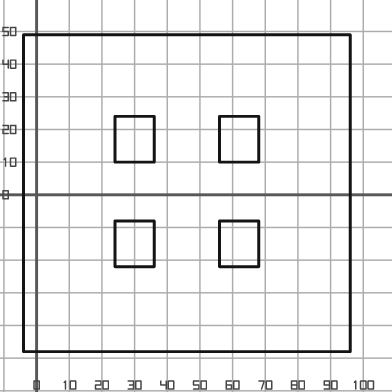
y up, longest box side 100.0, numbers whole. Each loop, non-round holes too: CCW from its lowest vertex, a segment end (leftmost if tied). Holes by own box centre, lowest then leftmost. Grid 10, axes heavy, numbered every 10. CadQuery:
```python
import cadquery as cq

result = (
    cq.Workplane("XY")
    .moveTo(-4.0, -48.0)
    .lineTo(96.0, -48.0)
    .lineTo(96.0, 49.0)
    .lineTo(-4.0, 49.0)
    .close()
    .moveTo(24.0, -22.0)
    .lineTo(36.0, -22.0)
    .lineTo(36.0, -8.0)
    .lineTo(24.0, -8.0)
    .close()
    .moveTo(56.0, -22.0)
    .lineTo(68.0, -22.0)
    .lineTo(68.0, -8.0)
    .lineTo(56.0, -8.0)
    .close()
    .moveTo(24.0, 10.0)
    .lineTo(36.0, 10.0)
    .lineTo(36.0, 24.0)
    .lineTo(24.0, 24.0)
    .close()
    .moveTo(56.0, 10.0)
    .lineTo(68.0, 10.0)
    .lineTo(68.0, 24.0)
    .lineTo(56.0, 24.0)
    .close()
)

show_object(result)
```